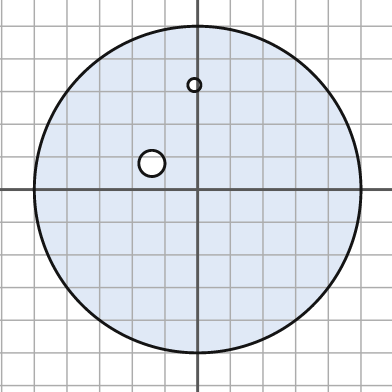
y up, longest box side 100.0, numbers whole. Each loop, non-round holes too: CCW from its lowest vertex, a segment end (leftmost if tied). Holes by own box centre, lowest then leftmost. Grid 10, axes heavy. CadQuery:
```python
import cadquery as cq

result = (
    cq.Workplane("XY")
    .moveTo(0.0, 0.0)
    .circle(50.0)
    .moveTo(-14.0, 8.0)
    .circle(4.0)
    .moveTo(-1.0, 32.0)
    .circle(2.0)
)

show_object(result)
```